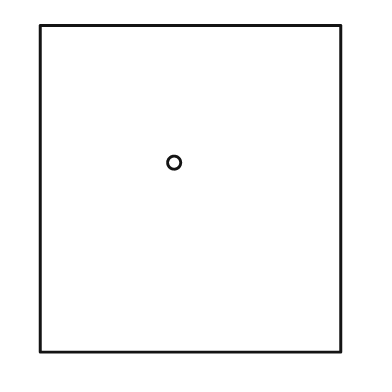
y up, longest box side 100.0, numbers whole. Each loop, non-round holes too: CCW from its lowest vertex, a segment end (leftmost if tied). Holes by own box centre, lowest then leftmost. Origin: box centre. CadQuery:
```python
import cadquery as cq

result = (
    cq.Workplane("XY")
    .moveTo(-46.0, -50.0)
    .lineTo(46.0, -50.0)
    .lineTo(46.0, 50.0)
    .lineTo(-46.0, 50.0)
    .close()
    .moveTo(-5.0, 8.0)
    .circle(2.0)
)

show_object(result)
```